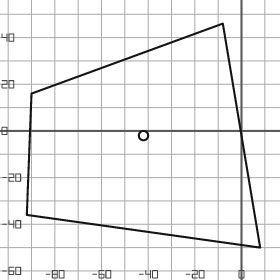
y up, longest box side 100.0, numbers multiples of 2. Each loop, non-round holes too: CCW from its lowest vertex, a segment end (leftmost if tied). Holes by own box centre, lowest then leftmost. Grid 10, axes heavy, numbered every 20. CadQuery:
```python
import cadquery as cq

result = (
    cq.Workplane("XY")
    .moveTo(8.0, -50.0)
    .lineTo(-8.0, 46.0)
    .lineTo(-90.0, 16.0)
    .lineTo(-92.0, -36.0)
    .close()
    .moveTo(-42.0, -2.0)
    .circle(2.0)
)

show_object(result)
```